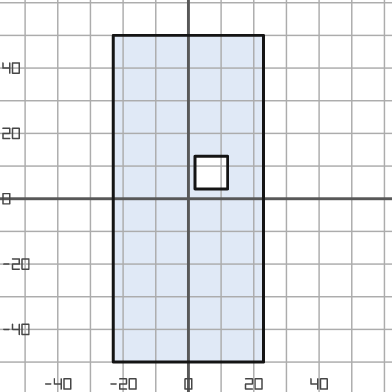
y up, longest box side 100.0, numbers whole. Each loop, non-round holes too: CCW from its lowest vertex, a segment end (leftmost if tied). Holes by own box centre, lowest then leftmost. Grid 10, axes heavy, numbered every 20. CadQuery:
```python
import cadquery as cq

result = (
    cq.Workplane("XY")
    .moveTo(-23.0, -50.0)
    .lineTo(23.0, -50.0)
    .lineTo(23.0, 50.0)
    .lineTo(-23.0, 50.0)
    .close()
    .moveTo(2.0, 3.0)
    .lineTo(12.0, 3.0)
    .lineTo(12.0, 13.0)
    .lineTo(2.0, 13.0)
    .close()
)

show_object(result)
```